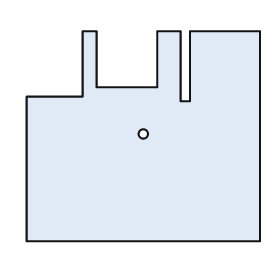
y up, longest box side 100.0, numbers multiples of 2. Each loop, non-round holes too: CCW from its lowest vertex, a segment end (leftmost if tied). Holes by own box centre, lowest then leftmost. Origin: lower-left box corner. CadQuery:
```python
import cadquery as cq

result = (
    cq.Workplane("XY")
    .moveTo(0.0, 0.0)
    .lineTo(100.0, 0.0)
    .lineTo(100.0, 90.0)
    .lineTo(70.0, 90.0)
    .lineTo(70.0, 60.0)
    .lineTo(66.0, 60.0)
    .lineTo(66.0, 90.0)
    .lineTo(56.0, 90.0)
    .lineTo(56.0, 66.0)
    .lineTo(30.0, 66.0)
    .lineTo(30.0, 90.0)
    .lineTo(24.0, 90.0)
    .lineTo(24.0, 62.0)
    .lineTo(0.0, 62.0)
    .close()
    .moveTo(50.0, 46.0)
    .circle(2.0)
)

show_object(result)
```